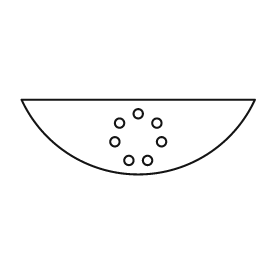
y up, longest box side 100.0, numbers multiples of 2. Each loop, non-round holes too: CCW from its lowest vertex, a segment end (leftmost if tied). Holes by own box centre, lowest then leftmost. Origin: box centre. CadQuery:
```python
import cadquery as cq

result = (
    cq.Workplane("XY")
    .moveTo(-50.0, 16.0)
    .threePointArc((0.0, -16.0), (50.0, 16.0))
    .close()
    .moveTo(-4.0, -10.0)
    .circle(2.0)
    .moveTo(4.0, -10.0)
    .circle(2.0)
    .moveTo(-10.0, -2.0)
    .circle(2.0)
    .moveTo(10.0, -2.0)
    .circle(2.0)
    .moveTo(-8.0, 6.0)
    .circle(2.0)
    .moveTo(8.0, 6.0)
    .circle(2.0)
    .moveTo(0.0, 10.0)
    .circle(2.0)
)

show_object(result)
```